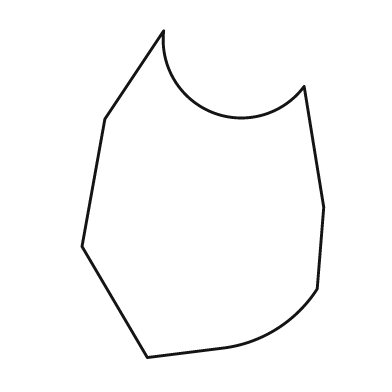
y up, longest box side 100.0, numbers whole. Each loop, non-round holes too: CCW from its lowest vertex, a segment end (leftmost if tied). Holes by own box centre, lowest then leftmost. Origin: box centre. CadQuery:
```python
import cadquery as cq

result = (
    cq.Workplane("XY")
    .moveTo(-17.0, -50.0)
    .lineTo(7.0, -47.0)
    .threePointArc((23.0, -41.0), (35.0, -29.0))
    .lineTo(37.0, -4.0)
    .lineTo(31.0, 33.0)
    .threePointArc((3.0, 25.0), (-12.0, 50.0))
    .lineTo(-30.0, 23.0)
    .lineTo(-37.0, -16.0)
    .close()
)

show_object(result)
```